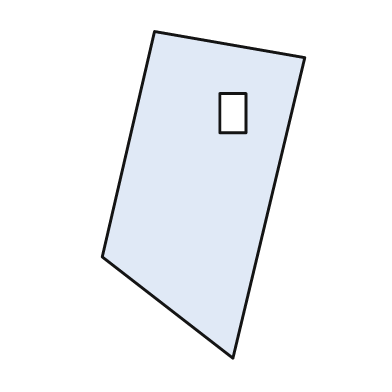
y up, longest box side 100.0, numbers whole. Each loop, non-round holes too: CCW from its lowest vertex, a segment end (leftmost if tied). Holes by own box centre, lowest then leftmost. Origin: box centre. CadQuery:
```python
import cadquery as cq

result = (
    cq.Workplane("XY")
    .moveTo(9.0, -50.0)
    .lineTo(31.0, 42.0)
    .lineTo(-15.0, 50.0)
    .lineTo(-31.0, -19.0)
    .close()
    .moveTo(5.0, 19.0)
    .lineTo(13.0, 19.0)
    .lineTo(13.0, 31.0)
    .lineTo(5.0, 31.0)
    .close()
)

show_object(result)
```